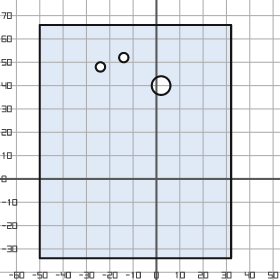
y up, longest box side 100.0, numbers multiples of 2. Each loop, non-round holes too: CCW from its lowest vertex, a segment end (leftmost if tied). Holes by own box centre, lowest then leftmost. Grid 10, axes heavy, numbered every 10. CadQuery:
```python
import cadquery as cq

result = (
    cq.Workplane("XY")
    .moveTo(-50.0, -34.0)
    .lineTo(32.0, -34.0)
    .lineTo(32.0, 66.0)
    .lineTo(-50.0, 66.0)
    .close()
    .moveTo(2.0, 40.0)
    .circle(4.0)
    .moveTo(-24.0, 48.0)
    .circle(2.0)
    .moveTo(-14.0, 52.0)
    .circle(2.0)
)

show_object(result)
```